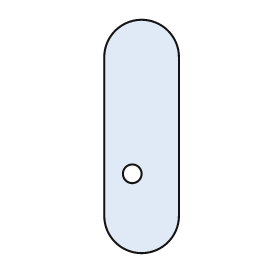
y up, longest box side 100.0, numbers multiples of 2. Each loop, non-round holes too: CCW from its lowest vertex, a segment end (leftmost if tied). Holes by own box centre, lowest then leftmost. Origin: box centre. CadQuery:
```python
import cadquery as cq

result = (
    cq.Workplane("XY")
    .moveTo(-16.0, -34.0)
    .threePointArc((0.0, -50.0), (16.0, -34.0))
    .lineTo(16.0, 34.0)
    .threePointArc((0.0, 50.0), (-16.0, 34.0))
    .close()
    .moveTo(-4.0, -16.0)
    .circle(4.0)
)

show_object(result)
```